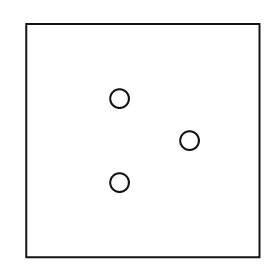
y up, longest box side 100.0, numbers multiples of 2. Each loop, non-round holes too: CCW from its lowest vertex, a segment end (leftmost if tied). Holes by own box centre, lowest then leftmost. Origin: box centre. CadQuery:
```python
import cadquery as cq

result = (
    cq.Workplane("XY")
    .moveTo(-50.0, -50.0)
    .lineTo(50.0, -50.0)
    .lineTo(50.0, 50.0)
    .lineTo(-50.0, 50.0)
    .close()
    .moveTo(-10.0, -18.0)
    .circle(4.0)
    .moveTo(20.0, 0.0)
    .circle(4.0)
    .moveTo(-10.0, 18.0)
    .circle(4.0)
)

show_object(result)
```